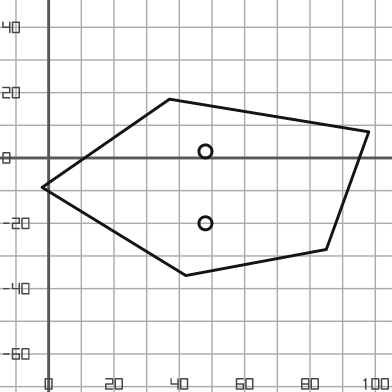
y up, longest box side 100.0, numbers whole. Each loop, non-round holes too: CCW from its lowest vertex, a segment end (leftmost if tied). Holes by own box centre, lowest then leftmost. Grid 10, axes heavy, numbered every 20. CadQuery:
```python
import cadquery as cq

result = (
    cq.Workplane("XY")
    .moveTo(42.0, -36.0)
    .lineTo(85.0, -28.0)
    .lineTo(98.0, 8.0)
    .lineTo(37.0, 18.0)
    .lineTo(-2.0, -9.0)
    .close()
    .moveTo(48.0, -20.0)
    .circle(2.0)
    .moveTo(48.0, 2.0)
    .circle(2.0)
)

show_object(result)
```